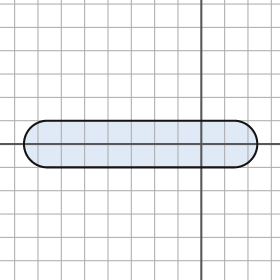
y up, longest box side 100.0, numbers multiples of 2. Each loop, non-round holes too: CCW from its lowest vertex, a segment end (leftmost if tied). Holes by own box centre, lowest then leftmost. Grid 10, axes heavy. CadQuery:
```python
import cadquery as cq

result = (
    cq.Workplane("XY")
    .moveTo(-66.0, -10.0)
    .lineTo(14.0, -10.0)
    .threePointArc((24.0, 0.0), (14.0, 10.0))
    .lineTo(-66.0, 10.0)
    .threePointArc((-76.0, 0.0), (-66.0, -10.0))
    .close()
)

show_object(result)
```